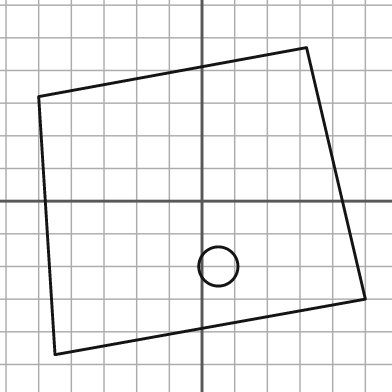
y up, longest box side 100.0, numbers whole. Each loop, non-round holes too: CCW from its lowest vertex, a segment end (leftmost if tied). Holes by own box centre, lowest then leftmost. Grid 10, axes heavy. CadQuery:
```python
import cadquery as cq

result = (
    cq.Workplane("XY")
    .moveTo(-45.0, -47.0)
    .lineTo(50.0, -30.0)
    .lineTo(32.0, 47.0)
    .lineTo(-50.0, 32.0)
    .close()
    .moveTo(5.0, -20.0)
    .circle(6.0)
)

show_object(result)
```